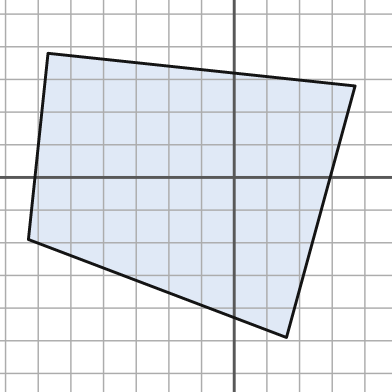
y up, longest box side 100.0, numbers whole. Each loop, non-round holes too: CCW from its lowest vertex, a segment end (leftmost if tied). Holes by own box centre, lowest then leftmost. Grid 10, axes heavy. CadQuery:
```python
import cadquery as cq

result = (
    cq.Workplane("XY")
    .moveTo(16.0, -49.0)
    .lineTo(37.0, 28.0)
    .lineTo(-57.0, 38.0)
    .lineTo(-63.0, -19.0)
    .close()
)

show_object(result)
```